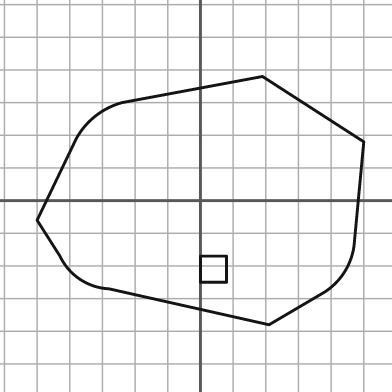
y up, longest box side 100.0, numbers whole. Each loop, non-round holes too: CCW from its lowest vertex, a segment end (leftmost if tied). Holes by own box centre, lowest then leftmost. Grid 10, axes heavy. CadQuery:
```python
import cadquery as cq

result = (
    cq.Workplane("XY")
    .moveTo(21.0, -38.0)
    .lineTo(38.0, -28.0)
    .threePointArc((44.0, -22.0), (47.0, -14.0))
    .lineTo(50.0, 18.0)
    .lineTo(19.0, 38.0)
    .lineTo(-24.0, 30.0)
    .threePointArc((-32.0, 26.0), (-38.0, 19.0))
    .lineTo(-50.0, -6.0)
    .lineTo(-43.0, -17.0)
    .threePointArc((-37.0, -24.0), (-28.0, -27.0))
    .close()
    .moveTo(0.0, -25.0)
    .lineTo(8.0, -25.0)
    .lineTo(8.0, -17.0)
    .lineTo(0.0, -17.0)
    .close()
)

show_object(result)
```